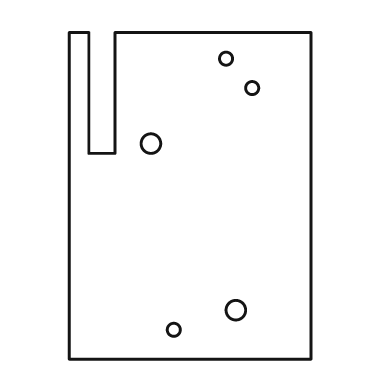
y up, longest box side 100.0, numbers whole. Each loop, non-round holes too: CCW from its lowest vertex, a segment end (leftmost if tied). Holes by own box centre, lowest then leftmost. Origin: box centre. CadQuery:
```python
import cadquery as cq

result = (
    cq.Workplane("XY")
    .moveTo(-37.0, -50.0)
    .lineTo(37.0, -50.0)
    .lineTo(37.0, 50.0)
    .lineTo(-23.0, 50.0)
    .lineTo(-23.0, 13.0)
    .lineTo(-31.0, 13.0)
    .lineTo(-31.0, 50.0)
    .lineTo(-37.0, 50.0)
    .close()
    .moveTo(-5.0, -41.0)
    .circle(2.0)
    .moveTo(14.0, -35.0)
    .circle(3.0)
    .moveTo(-12.0, 16.0)
    .circle(3.0)
    .moveTo(19.0, 33.0)
    .circle(2.0)
    .moveTo(11.0, 42.0)
    .circle(2.0)
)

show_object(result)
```